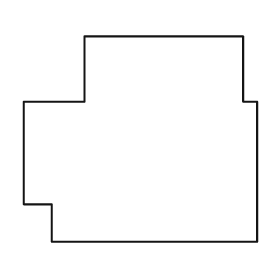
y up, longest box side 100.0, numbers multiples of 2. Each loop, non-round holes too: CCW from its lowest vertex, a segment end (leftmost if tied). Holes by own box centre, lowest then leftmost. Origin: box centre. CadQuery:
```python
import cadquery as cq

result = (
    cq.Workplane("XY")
    .moveTo(-38.0, -44.0)
    .lineTo(50.0, -44.0)
    .lineTo(50.0, 16.0)
    .lineTo(44.0, 16.0)
    .lineTo(44.0, 44.0)
    .lineTo(-24.0, 44.0)
    .lineTo(-24.0, 16.0)
    .lineTo(-50.0, 16.0)
    .lineTo(-50.0, -28.0)
    .lineTo(-38.0, -28.0)
    .close()
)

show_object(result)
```